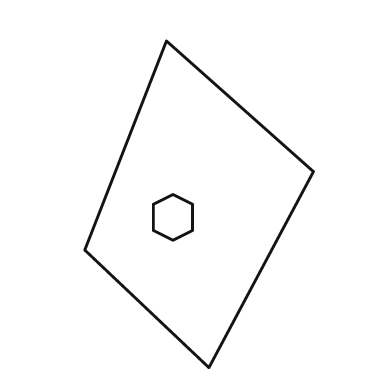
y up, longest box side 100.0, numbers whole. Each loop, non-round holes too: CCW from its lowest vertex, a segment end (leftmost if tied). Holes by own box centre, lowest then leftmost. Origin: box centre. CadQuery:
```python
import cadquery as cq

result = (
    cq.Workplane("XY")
    .moveTo(3.0, -50.0)
    .lineTo(35.0, 10.0)
    .lineTo(-10.0, 50.0)
    .lineTo(-35.0, -14.0)
    .close()
    .moveTo(-8.0, -11.0)
    .lineTo(-2.0, -8.0)
    .lineTo(-2.0, 0.0)
    .lineTo(-8.0, 3.0)
    .lineTo(-14.0, 0.0)
    .lineTo(-14.0, -8.0)
    .close()
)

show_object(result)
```